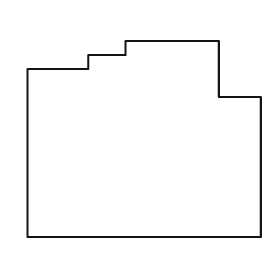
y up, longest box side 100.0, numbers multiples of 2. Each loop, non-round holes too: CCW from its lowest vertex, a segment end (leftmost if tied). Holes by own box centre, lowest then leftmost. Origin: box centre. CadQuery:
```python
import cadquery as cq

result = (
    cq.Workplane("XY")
    .moveTo(-50.0, -42.0)
    .lineTo(50.0, -42.0)
    .lineTo(50.0, 18.0)
    .lineTo(32.0, 18.0)
    .lineTo(32.0, 42.0)
    .lineTo(-8.0, 42.0)
    .lineTo(-8.0, 36.0)
    .lineTo(-24.0, 36.0)
    .lineTo(-24.0, 30.0)
    .lineTo(-50.0, 30.0)
    .close()
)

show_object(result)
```